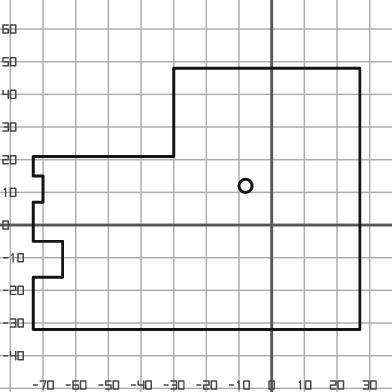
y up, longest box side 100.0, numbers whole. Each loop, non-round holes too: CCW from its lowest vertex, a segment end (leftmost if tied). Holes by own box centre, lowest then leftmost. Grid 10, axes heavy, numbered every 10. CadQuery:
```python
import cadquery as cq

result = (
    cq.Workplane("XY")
    .moveTo(-73.0, -32.0)
    .lineTo(27.0, -32.0)
    .lineTo(27.0, 48.0)
    .lineTo(-30.0, 48.0)
    .lineTo(-30.0, 21.0)
    .lineTo(-73.0, 21.0)
    .lineTo(-73.0, 15.0)
    .lineTo(-70.0, 15.0)
    .lineTo(-70.0, 7.0)
    .lineTo(-73.0, 7.0)
    .lineTo(-73.0, -5.0)
    .lineTo(-64.0, -5.0)
    .lineTo(-64.0, -16.0)
    .lineTo(-73.0, -16.0)
    .close()
    .moveTo(-8.0, 12.0)
    .circle(2.0)
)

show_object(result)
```